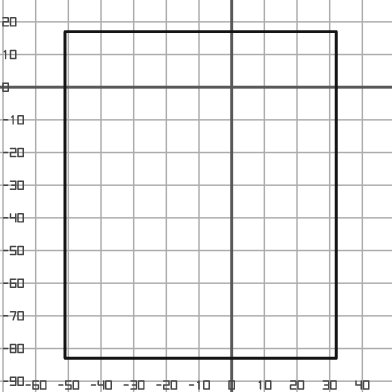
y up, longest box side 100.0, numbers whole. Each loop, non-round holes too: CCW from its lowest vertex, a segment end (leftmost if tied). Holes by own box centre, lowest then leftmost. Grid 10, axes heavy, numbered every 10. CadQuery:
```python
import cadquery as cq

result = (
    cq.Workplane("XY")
    .moveTo(-51.0, -83.0)
    .lineTo(32.0, -83.0)
    .lineTo(32.0, 17.0)
    .lineTo(-51.0, 17.0)
    .close()
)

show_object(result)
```